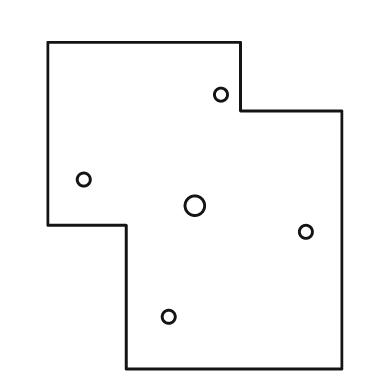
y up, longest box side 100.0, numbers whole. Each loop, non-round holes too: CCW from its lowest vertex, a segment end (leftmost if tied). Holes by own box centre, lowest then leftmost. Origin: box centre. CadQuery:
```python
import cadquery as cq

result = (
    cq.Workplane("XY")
    .moveTo(-21.0, -50.0)
    .lineTo(45.0, -50.0)
    .lineTo(45.0, 29.0)
    .lineTo(14.0, 29.0)
    .lineTo(14.0, 50.0)
    .lineTo(-45.0, 50.0)
    .lineTo(-45.0, -6.0)
    .lineTo(-21.0, -6.0)
    .close()
    .moveTo(-8.0, -34.0)
    .circle(2.0)
    .moveTo(34.0, -8.0)
    .circle(2.0)
    .moveTo(0.0, 0.0)
    .circle(3.0)
    .moveTo(-34.0, 8.0)
    .circle(2.0)
    .moveTo(8.0, 34.0)
    .circle(2.0)
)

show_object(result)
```